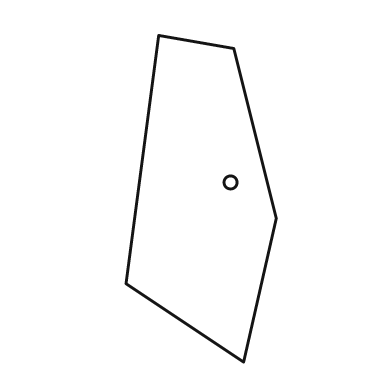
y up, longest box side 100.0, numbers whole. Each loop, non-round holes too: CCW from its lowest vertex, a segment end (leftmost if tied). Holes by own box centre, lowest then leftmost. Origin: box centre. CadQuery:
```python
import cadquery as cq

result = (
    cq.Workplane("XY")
    .moveTo(13.0, -50.0)
    .lineTo(23.0, -6.0)
    .lineTo(10.0, 46.0)
    .lineTo(-13.0, 50.0)
    .lineTo(-23.0, -26.0)
    .close()
    .moveTo(9.0, 5.0)
    .circle(2.0)
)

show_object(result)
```